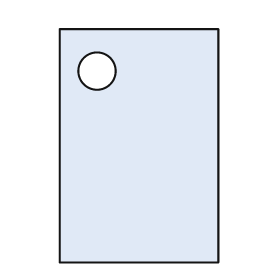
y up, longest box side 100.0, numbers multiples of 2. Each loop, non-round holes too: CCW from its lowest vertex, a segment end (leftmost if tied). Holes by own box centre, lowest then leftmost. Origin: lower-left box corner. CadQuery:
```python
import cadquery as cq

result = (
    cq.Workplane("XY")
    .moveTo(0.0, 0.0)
    .lineTo(68.0, 0.0)
    .lineTo(68.0, 100.0)
    .lineTo(0.0, 100.0)
    .close()
    .moveTo(16.0, 82.0)
    .circle(8.0)
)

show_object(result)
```